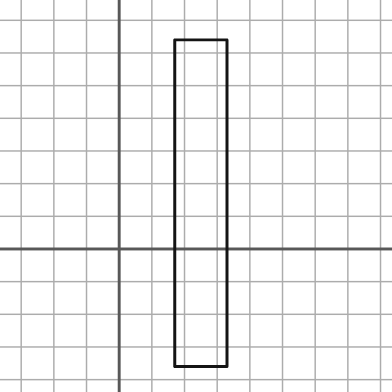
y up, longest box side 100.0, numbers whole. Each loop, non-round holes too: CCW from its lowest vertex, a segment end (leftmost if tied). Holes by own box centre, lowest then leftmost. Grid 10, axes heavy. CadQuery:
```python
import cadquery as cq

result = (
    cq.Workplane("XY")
    .moveTo(17.0, -36.0)
    .lineTo(33.0, -36.0)
    .lineTo(33.0, 64.0)
    .lineTo(17.0, 64.0)
    .close()
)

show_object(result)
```